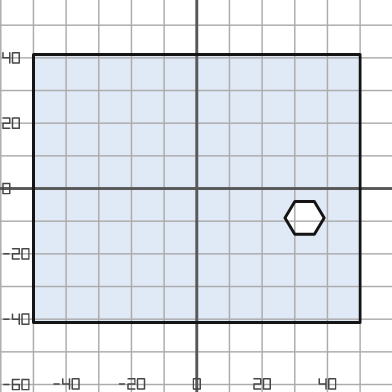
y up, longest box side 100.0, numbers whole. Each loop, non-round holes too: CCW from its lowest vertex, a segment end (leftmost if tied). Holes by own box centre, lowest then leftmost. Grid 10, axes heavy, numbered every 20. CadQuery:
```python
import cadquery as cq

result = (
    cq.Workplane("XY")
    .moveTo(-50.0, -41.0)
    .lineTo(50.0, -41.0)
    .lineTo(50.0, 41.0)
    .lineTo(-50.0, 41.0)
    .close()
    .moveTo(30.0, -14.0)
    .lineTo(36.0, -14.0)
    .lineTo(39.0, -9.0)
    .lineTo(36.0, -4.0)
    .lineTo(30.0, -4.0)
    .lineTo(27.0, -9.0)
    .close()
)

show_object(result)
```